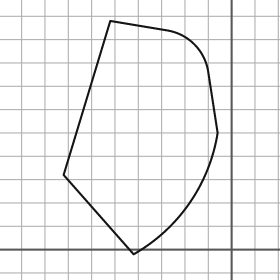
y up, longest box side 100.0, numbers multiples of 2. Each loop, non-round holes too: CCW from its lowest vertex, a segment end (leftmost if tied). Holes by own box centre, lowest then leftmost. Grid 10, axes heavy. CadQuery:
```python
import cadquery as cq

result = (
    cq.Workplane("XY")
    .moveTo(-42.0, -2.0)
    .threePointArc((-18.0, 20.0), (-6.0, 50.0))
    .lineTo(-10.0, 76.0)
    .threePointArc((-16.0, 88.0), (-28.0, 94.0))
    .lineTo(-52.0, 98.0)
    .lineTo(-72.0, 32.0)
    .close()
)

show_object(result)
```